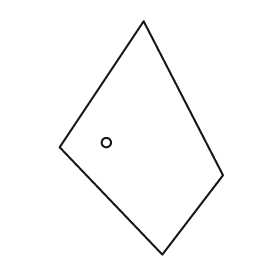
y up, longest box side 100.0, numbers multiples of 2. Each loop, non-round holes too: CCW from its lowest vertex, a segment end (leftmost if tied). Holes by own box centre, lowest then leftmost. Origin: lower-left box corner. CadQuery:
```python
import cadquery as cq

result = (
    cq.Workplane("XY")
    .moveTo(44.0, 0.0)
    .lineTo(70.0, 34.0)
    .lineTo(36.0, 100.0)
    .lineTo(0.0, 46.0)
    .close()
    .moveTo(20.0, 48.0)
    .circle(2.0)
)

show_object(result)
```